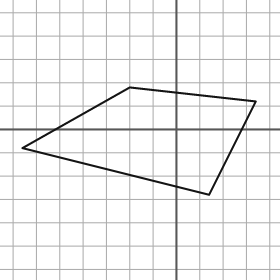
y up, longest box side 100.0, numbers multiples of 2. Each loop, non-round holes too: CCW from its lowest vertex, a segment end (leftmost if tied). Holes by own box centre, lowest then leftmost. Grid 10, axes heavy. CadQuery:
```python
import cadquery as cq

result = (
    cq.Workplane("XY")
    .moveTo(14.0, -28.0)
    .lineTo(34.0, 12.0)
    .lineTo(-20.0, 18.0)
    .lineTo(-66.0, -8.0)
    .close()
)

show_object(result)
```